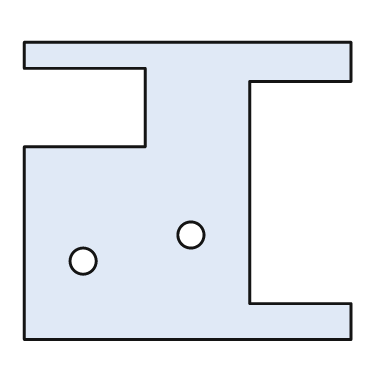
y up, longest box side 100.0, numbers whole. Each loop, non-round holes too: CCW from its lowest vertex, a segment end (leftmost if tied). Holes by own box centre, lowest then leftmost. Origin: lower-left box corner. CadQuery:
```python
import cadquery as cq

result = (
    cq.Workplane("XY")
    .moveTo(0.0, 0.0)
    .lineTo(100.0, 0.0)
    .lineTo(100.0, 11.0)
    .lineTo(69.0, 11.0)
    .lineTo(69.0, 79.0)
    .lineTo(100.0, 79.0)
    .lineTo(100.0, 91.0)
    .lineTo(0.0, 91.0)
    .lineTo(0.0, 83.0)
    .lineTo(37.0, 83.0)
    .lineTo(37.0, 59.0)
    .lineTo(0.0, 59.0)
    .close()
    .moveTo(18.0, 24.0)
    .circle(4.0)
    .moveTo(51.0, 32.0)
    .circle(4.0)
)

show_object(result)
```